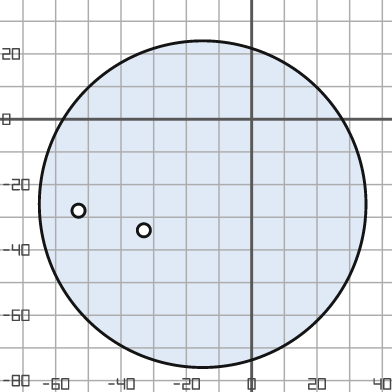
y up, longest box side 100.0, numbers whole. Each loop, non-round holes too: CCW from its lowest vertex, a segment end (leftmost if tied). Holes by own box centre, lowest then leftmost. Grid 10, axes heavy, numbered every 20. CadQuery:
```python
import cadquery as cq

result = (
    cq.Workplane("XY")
    .moveTo(-15.0, -26.0)
    .circle(50.0)
    .moveTo(-33.0, -34.0)
    .circle(2.0)
    .moveTo(-53.0, -28.0)
    .circle(2.0)
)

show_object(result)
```